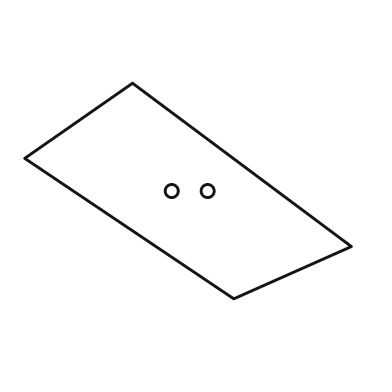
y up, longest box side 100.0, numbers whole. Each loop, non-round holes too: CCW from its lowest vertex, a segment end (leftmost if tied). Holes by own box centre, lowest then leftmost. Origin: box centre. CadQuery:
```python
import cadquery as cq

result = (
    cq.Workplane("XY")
    .moveTo(14.0, -33.0)
    .lineTo(50.0, -17.0)
    .lineTo(-17.0, 33.0)
    .lineTo(-50.0, 10.0)
    .close()
    .moveTo(-5.0, 0.0)
    .circle(2.0)
    .moveTo(6.0, 0.0)
    .circle(2.0)
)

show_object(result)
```